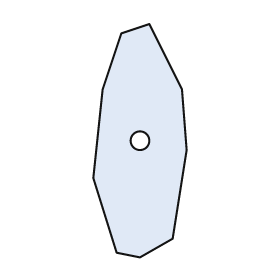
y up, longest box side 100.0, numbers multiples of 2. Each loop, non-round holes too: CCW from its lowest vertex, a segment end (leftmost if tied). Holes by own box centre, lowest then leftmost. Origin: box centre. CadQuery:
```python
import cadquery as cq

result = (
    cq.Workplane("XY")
    .moveTo(0.0, -50.0)
    .lineTo(14.0, -42.0)
    .lineTo(20.0, -4.0)
    .lineTo(18.0, 22.0)
    .lineTo(4.0, 50.0)
    .lineTo(-8.0, 46.0)
    .lineTo(-16.0, 22.0)
    .lineTo(-20.0, -16.0)
    .lineTo(-10.0, -48.0)
    .close()
    .moveTo(0.0, 0.0)
    .circle(4.0)
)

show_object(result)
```